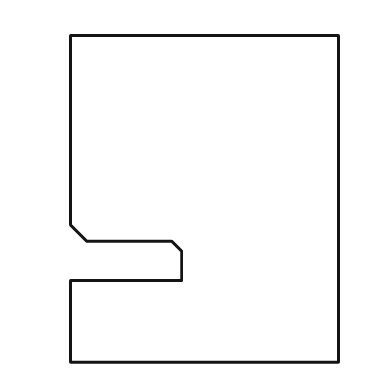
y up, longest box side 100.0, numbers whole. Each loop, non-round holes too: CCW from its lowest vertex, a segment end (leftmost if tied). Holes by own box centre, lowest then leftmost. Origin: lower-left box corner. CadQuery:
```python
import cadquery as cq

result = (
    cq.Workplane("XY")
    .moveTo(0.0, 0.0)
    .lineTo(82.0, 0.0)
    .lineTo(82.0, 100.0)
    .lineTo(0.0, 100.0)
    .lineTo(0.0, 42.0)
    .lineTo(5.0, 37.0)
    .lineTo(31.0, 37.0)
    .lineTo(34.0, 34.0)
    .lineTo(34.0, 25.0)
    .lineTo(0.0, 25.0)
    .close()
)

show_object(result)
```